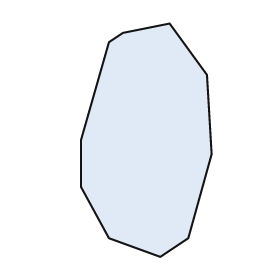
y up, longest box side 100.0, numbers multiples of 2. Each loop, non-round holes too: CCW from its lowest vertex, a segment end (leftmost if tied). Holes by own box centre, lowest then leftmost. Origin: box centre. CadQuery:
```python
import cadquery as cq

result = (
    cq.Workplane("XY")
    .moveTo(6.0, -50.0)
    .lineTo(18.0, -42.0)
    .lineTo(28.0, -6.0)
    .lineTo(26.0, 28.0)
    .lineTo(10.0, 50.0)
    .lineTo(-10.0, 46.0)
    .lineTo(-16.0, 42.0)
    .lineTo(-28.0, 0.0)
    .lineTo(-28.0, -20.0)
    .lineTo(-16.0, -42.0)
    .close()
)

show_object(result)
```